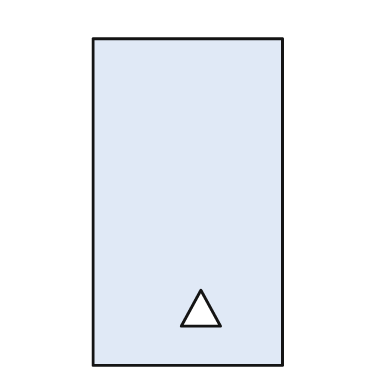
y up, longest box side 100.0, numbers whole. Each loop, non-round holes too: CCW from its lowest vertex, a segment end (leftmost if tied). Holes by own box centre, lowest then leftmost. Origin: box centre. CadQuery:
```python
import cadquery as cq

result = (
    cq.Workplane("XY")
    .moveTo(-29.0, -50.0)
    .lineTo(29.0, -50.0)
    .lineTo(29.0, 50.0)
    .lineTo(-29.0, 50.0)
    .close()
    .moveTo(-2.0, -38.0)
    .lineTo(10.0, -38.0)
    .lineTo(4.0, -27.0)
    .close()
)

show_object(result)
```